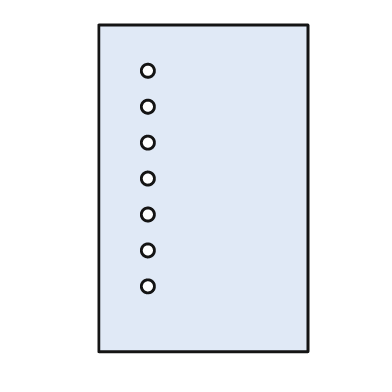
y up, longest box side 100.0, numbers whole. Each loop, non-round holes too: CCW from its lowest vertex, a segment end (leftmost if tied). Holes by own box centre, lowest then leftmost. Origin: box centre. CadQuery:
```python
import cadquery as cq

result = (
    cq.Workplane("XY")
    .moveTo(-32.0, -50.0)
    .lineTo(32.0, -50.0)
    .lineTo(32.0, 50.0)
    .lineTo(-32.0, 50.0)
    .close()
    .moveTo(-17.0, -30.0)
    .circle(2.0)
    .moveTo(-17.0, -19.0)
    .circle(2.0)
    .moveTo(-17.0, -8.0)
    .circle(2.0)
    .moveTo(-17.0, 3.0)
    .circle(2.0)
    .moveTo(-17.0, 14.0)
    .circle(2.0)
    .moveTo(-17.0, 25.0)
    .circle(2.0)
    .moveTo(-17.0, 36.0)
    .circle(2.0)
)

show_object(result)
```